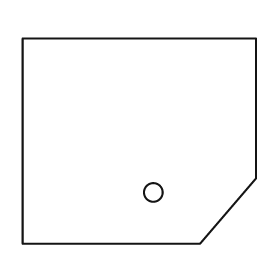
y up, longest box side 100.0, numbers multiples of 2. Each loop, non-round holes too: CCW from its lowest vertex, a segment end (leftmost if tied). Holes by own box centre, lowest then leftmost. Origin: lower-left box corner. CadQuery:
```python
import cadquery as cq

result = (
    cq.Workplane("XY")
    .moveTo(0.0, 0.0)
    .lineTo(76.0, 0.0)
    .lineTo(100.0, 28.0)
    .lineTo(100.0, 88.0)
    .lineTo(0.0, 88.0)
    .close()
    .moveTo(56.0, 22.0)
    .circle(4.0)
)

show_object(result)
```